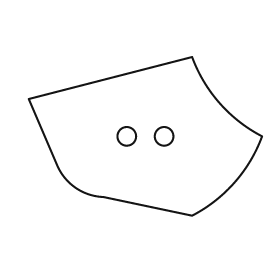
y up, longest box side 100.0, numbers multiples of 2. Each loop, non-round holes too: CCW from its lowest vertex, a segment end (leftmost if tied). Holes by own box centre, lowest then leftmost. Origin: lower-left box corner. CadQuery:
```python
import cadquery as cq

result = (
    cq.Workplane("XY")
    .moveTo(70.0, 0.0)
    .threePointArc((88.0, 14.0), (100.0, 34.0))
    .threePointArc((82.0, 48.0), (70.0, 68.0))
    .lineTo(0.0, 50.0)
    .lineTo(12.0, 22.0)
    .threePointArc((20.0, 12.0), (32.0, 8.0))
    .close()
    .moveTo(42.0, 34.0)
    .circle(4.0)
    .moveTo(58.0, 34.0)
    .circle(4.0)
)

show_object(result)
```